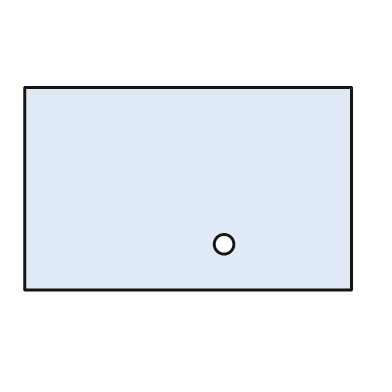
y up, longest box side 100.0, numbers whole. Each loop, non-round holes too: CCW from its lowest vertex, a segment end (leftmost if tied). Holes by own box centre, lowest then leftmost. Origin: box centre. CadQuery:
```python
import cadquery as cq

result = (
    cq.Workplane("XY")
    .moveTo(-50.0, -31.0)
    .lineTo(50.0, -31.0)
    .lineTo(50.0, 31.0)
    .lineTo(-50.0, 31.0)
    .close()
    .moveTo(11.0, -17.0)
    .circle(3.0)
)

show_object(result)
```